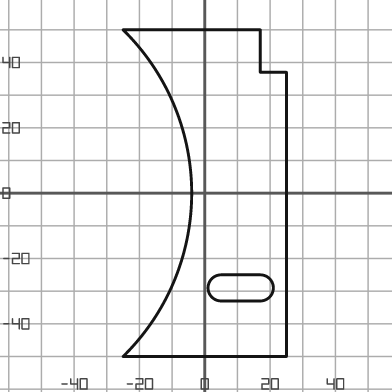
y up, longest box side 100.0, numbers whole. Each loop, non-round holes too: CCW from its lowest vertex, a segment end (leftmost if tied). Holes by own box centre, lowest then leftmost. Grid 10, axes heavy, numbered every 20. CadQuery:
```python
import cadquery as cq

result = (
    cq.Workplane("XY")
    .moveTo(-25.0, -50.0)
    .lineTo(25.0, -50.0)
    .lineTo(25.0, 37.0)
    .lineTo(17.0, 37.0)
    .lineTo(17.0, 50.0)
    .lineTo(-25.0, 50.0)
    .threePointArc((-4.0, 0.0), (-25.0, -50.0))
    .close()
    .moveTo(5.0, -33.0)
    .lineTo(17.0, -33.0)
    .threePointArc((21.0, -29.0), (17.0, -25.0))
    .lineTo(5.0, -25.0)
    .threePointArc((1.0, -29.0), (5.0, -33.0))
    .close()
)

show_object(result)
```